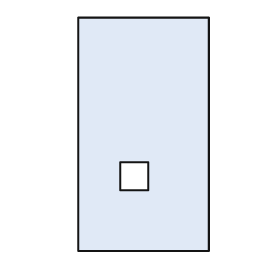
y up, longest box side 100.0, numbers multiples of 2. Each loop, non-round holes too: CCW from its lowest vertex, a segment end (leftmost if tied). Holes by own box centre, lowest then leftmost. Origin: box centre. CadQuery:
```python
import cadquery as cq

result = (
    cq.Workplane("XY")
    .moveTo(-28.0, -50.0)
    .lineTo(28.0, -50.0)
    .lineTo(28.0, 50.0)
    .lineTo(-28.0, 50.0)
    .close()
    .moveTo(-10.0, -24.0)
    .lineTo(2.0, -24.0)
    .lineTo(2.0, -12.0)
    .lineTo(-10.0, -12.0)
    .close()
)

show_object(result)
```